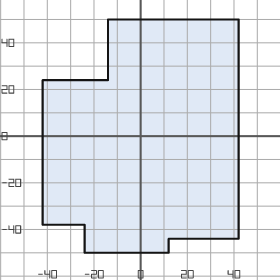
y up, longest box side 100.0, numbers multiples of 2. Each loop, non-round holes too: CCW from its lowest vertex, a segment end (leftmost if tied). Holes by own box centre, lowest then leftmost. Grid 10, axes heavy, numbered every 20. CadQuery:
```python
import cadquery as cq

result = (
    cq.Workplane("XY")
    .moveTo(-24.0, -50.0)
    .lineTo(12.0, -50.0)
    .lineTo(12.0, -44.0)
    .lineTo(42.0, -44.0)
    .lineTo(42.0, 50.0)
    .lineTo(-14.0, 50.0)
    .lineTo(-14.0, 24.0)
    .lineTo(-42.0, 24.0)
    .lineTo(-42.0, -38.0)
    .lineTo(-24.0, -38.0)
    .close()
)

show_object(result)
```